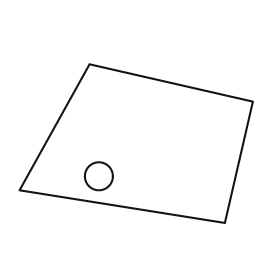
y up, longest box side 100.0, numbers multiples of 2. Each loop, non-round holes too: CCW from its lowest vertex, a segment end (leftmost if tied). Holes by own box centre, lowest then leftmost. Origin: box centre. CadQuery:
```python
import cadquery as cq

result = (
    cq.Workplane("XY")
    .moveTo(38.0, -34.0)
    .lineTo(50.0, 18.0)
    .lineTo(-20.0, 34.0)
    .lineTo(-50.0, -20.0)
    .close()
    .moveTo(-16.0, -14.0)
    .circle(6.0)
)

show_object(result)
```